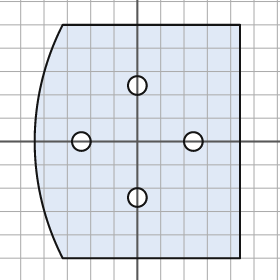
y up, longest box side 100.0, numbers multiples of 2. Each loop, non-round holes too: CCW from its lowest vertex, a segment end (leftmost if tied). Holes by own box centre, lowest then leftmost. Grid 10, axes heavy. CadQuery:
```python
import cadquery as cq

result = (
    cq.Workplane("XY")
    .moveTo(-32.0, -50.0)
    .lineTo(44.0, -50.0)
    .lineTo(44.0, 50.0)
    .lineTo(-32.0, 50.0)
    .threePointArc((-44.0, 0.0), (-32.0, -50.0))
    .close()
    .moveTo(0.0, -24.0)
    .circle(4.0)
    .moveTo(-24.0, 0.0)
    .circle(4.0)
    .moveTo(24.0, 0.0)
    .circle(4.0)
    .moveTo(0.0, 24.0)
    .circle(4.0)
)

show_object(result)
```